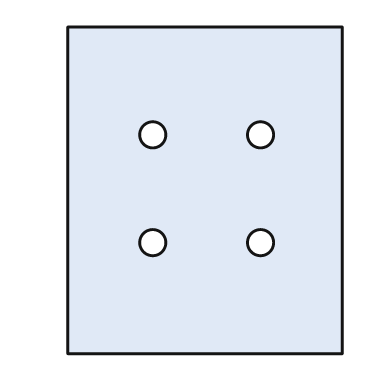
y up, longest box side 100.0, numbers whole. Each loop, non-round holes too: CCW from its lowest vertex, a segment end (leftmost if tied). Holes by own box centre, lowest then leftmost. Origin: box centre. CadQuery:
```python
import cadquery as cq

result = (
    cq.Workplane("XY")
    .moveTo(-42.0, -50.0)
    .lineTo(42.0, -50.0)
    .lineTo(42.0, 50.0)
    .lineTo(-42.0, 50.0)
    .close()
    .moveTo(-16.0, -16.0)
    .circle(4.0)
    .moveTo(17.0, -16.0)
    .circle(4.0)
    .moveTo(-16.0, 17.0)
    .circle(4.0)
    .moveTo(17.0, 17.0)
    .circle(4.0)
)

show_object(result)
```